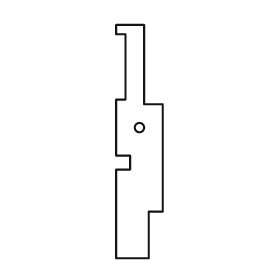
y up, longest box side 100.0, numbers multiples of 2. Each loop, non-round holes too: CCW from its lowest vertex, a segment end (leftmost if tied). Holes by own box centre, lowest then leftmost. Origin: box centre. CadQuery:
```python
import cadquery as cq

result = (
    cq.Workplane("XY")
    .moveTo(-10.0, -50.0)
    .lineTo(4.0, -50.0)
    .lineTo(4.0, -30.0)
    .lineTo(10.0, -30.0)
    .lineTo(10.0, 16.0)
    .lineTo(2.0, 16.0)
    .lineTo(2.0, 50.0)
    .lineTo(-10.0, 50.0)
    .lineTo(-10.0, 46.0)
    .lineTo(-6.0, 46.0)
    .lineTo(-6.0, 18.0)
    .lineTo(-10.0, 18.0)
    .lineTo(-10.0, -6.0)
    .lineTo(-4.0, -6.0)
    .lineTo(-4.0, -12.0)
    .lineTo(-10.0, -12.0)
    .close()
    .moveTo(0.0, 6.0)
    .circle(2.0)
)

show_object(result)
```